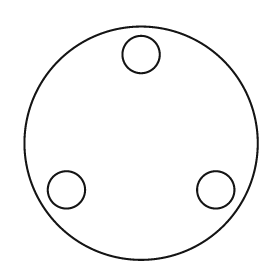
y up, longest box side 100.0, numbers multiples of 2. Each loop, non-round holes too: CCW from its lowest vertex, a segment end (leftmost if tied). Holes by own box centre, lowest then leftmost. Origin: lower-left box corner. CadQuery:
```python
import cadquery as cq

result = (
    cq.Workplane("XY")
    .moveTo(50.0, 50.0)
    .circle(50.0)
    .moveTo(18.0, 30.0)
    .circle(8.0)
    .moveTo(82.0, 30.0)
    .circle(8.0)
    .moveTo(50.0, 88.0)
    .circle(8.0)
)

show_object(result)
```